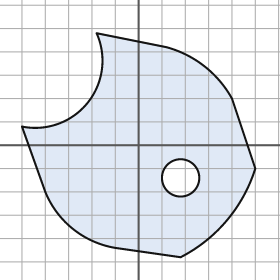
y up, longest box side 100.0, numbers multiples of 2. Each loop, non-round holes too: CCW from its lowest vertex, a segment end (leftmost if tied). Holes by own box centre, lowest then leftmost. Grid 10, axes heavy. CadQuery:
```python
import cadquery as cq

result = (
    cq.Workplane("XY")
    .moveTo(18.0, -48.0)
    .threePointArc((38.0, -32.0), (50.0, -10.0))
    .lineTo(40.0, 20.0)
    .threePointArc((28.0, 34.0), (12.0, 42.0))
    .lineTo(-18.0, 48.0)
    .threePointArc((-22.0, 18.0), (-50.0, 8.0))
    .lineTo(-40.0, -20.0)
    .threePointArc((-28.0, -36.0), (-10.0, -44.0))
    .close()
    .moveTo(18.0, -14.0)
    .circle(8.0)
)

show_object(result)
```